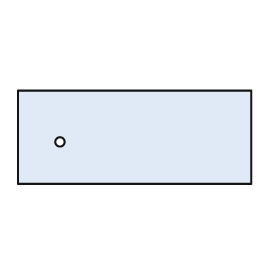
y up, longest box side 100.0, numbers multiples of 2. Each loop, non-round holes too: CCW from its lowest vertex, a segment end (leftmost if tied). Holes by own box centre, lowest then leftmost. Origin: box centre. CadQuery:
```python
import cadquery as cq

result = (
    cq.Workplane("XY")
    .moveTo(-50.0, -20.0)
    .lineTo(50.0, -20.0)
    .lineTo(50.0, 20.0)
    .lineTo(-50.0, 20.0)
    .close()
    .moveTo(-32.0, -2.0)
    .circle(2.0)
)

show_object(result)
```